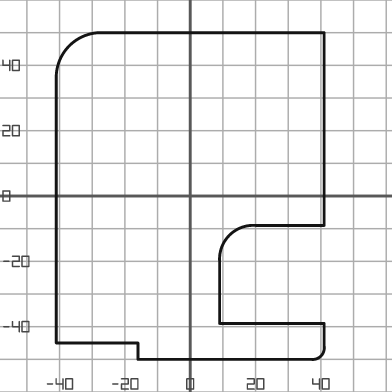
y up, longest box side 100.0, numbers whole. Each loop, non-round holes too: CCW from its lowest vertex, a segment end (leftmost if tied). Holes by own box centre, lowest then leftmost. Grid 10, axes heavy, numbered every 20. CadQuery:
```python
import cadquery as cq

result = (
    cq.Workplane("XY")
    .moveTo(-16.0, -50.0)
    .lineTo(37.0, -50.0)
    .threePointArc((40.0, -49.0), (41.0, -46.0))
    .lineTo(41.0, -39.0)
    .lineTo(9.0, -39.0)
    .lineTo(9.0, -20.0)
    .threePointArc((12.0, -12.0), (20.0, -9.0))
    .lineTo(41.0, -9.0)
    .lineTo(41.0, 50.0)
    .lineTo(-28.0, 50.0)
    .threePointArc((-37.0, 46.0), (-41.0, 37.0))
    .lineTo(-41.0, -45.0)
    .lineTo(-16.0, -45.0)
    .close()
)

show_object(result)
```